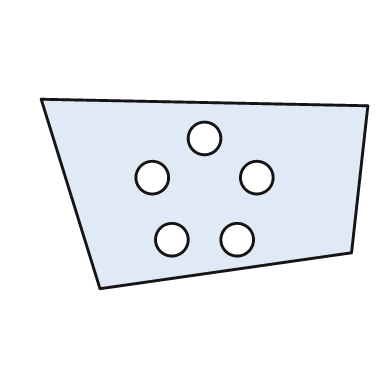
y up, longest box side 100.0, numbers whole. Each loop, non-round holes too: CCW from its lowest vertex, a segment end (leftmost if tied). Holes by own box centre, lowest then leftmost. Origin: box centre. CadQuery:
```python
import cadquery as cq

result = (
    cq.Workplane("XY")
    .moveTo(-32.0, -29.0)
    .lineTo(45.0, -18.0)
    .lineTo(50.0, 27.0)
    .lineTo(-50.0, 29.0)
    .close()
    .moveTo(-10.0, -14.0)
    .circle(5.0)
    .moveTo(10.0, -14.0)
    .circle(5.0)
    .moveTo(-16.0, 5.0)
    .circle(5.0)
    .moveTo(16.0, 5.0)
    .circle(5.0)
    .moveTo(0.0, 17.0)
    .circle(5.0)
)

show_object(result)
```